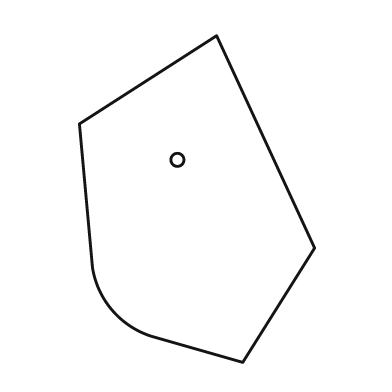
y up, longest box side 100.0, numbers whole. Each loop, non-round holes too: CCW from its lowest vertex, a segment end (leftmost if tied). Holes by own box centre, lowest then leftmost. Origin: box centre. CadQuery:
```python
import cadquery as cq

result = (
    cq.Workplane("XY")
    .moveTo(14.0, -50.0)
    .lineTo(36.0, -15.0)
    .lineTo(6.0, 50.0)
    .lineTo(-36.0, 23.0)
    .lineTo(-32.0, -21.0)
    .threePointArc((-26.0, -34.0), (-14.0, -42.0))
    .close()
    .moveTo(-6.0, 12.0)
    .circle(2.0)
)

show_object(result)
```